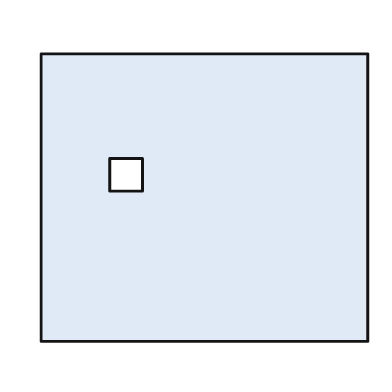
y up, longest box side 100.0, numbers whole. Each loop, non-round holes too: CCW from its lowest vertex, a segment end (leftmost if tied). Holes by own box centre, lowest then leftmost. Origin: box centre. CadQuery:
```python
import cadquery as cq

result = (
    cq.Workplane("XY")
    .moveTo(-50.0, -44.0)
    .lineTo(50.0, -44.0)
    .lineTo(50.0, 44.0)
    .lineTo(-50.0, 44.0)
    .close()
    .moveTo(-29.0, 2.0)
    .lineTo(-19.0, 2.0)
    .lineTo(-19.0, 12.0)
    .lineTo(-29.0, 12.0)
    .close()
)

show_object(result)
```